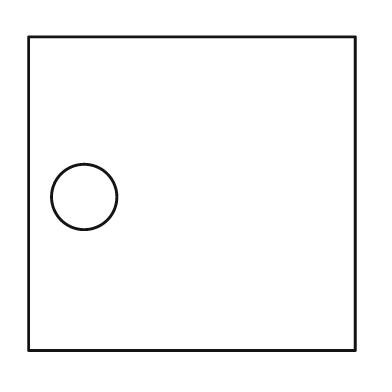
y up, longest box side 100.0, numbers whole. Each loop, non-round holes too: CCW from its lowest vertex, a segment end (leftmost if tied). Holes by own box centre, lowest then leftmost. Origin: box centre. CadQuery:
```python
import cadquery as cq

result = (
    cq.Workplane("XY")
    .moveTo(-50.0, -48.0)
    .lineTo(50.0, -48.0)
    .lineTo(50.0, 48.0)
    .lineTo(-50.0, 48.0)
    .close()
    .moveTo(-33.0, -1.0)
    .circle(10.0)
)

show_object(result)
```